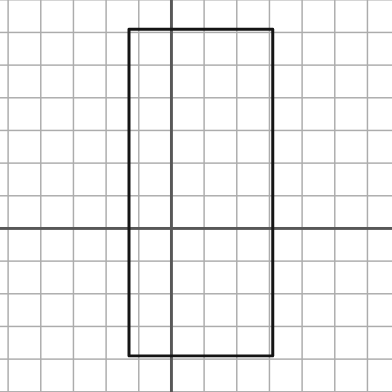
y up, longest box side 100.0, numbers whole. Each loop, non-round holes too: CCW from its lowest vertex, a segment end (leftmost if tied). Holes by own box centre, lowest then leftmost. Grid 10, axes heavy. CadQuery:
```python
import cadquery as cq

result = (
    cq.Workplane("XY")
    .moveTo(-13.0, -39.0)
    .lineTo(31.0, -39.0)
    .lineTo(31.0, 61.0)
    .lineTo(-13.0, 61.0)
    .close()
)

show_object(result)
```